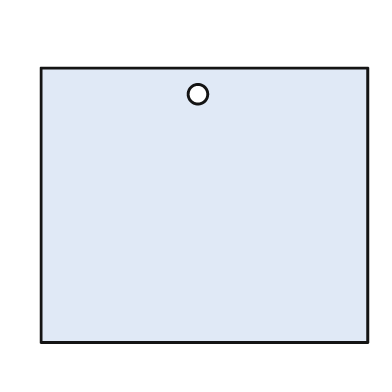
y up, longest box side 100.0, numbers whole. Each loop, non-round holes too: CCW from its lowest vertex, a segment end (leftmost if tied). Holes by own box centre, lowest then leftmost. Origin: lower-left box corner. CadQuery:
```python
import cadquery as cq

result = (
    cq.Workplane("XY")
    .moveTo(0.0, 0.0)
    .lineTo(100.0, 0.0)
    .lineTo(100.0, 84.0)
    .lineTo(0.0, 84.0)
    .close()
    .moveTo(48.0, 76.0)
    .circle(3.0)
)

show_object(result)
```